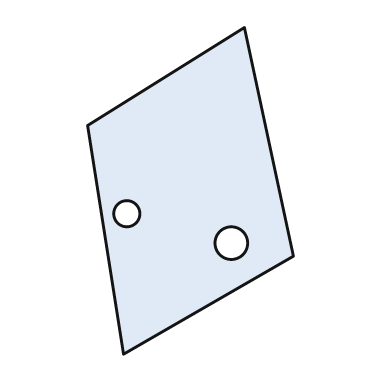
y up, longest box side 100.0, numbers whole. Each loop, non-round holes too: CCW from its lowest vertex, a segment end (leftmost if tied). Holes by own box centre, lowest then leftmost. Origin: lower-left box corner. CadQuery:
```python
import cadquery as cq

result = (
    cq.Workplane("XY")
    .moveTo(11.0, 0.0)
    .lineTo(63.0, 30.0)
    .lineTo(48.0, 100.0)
    .lineTo(0.0, 70.0)
    .close()
    .moveTo(44.0, 34.0)
    .circle(5.0)
    .moveTo(12.0, 43.0)
    .circle(4.0)
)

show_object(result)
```